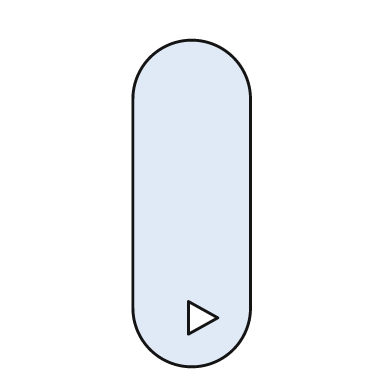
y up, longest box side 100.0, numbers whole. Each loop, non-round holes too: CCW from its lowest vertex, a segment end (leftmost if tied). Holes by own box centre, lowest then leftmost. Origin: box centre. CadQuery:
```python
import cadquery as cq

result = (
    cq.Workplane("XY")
    .moveTo(-18.0, -32.0)
    .threePointArc((0.0, -50.0), (18.0, -32.0))
    .lineTo(18.0, 32.0)
    .threePointArc((0.0, 50.0), (-18.0, 32.0))
    .close()
    .moveTo(-1.0, -40.0)
    .lineTo(8.0, -35.0)
    .lineTo(-1.0, -30.0)
    .close()
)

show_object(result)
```